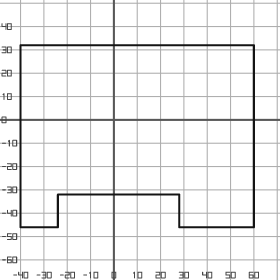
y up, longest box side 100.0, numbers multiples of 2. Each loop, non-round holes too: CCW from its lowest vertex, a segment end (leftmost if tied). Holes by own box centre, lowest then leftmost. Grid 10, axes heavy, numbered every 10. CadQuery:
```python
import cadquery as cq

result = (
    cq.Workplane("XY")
    .moveTo(-40.0, -46.0)
    .lineTo(-24.0, -46.0)
    .lineTo(-24.0, -32.0)
    .lineTo(28.0, -32.0)
    .lineTo(28.0, -46.0)
    .lineTo(60.0, -46.0)
    .lineTo(60.0, 32.0)
    .lineTo(-40.0, 32.0)
    .close()
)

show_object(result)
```